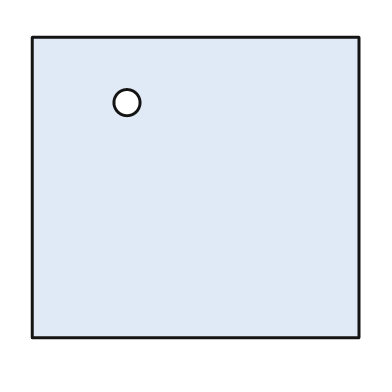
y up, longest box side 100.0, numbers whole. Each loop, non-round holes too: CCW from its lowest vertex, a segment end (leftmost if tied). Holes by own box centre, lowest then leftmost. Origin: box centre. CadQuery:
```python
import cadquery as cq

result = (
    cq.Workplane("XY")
    .moveTo(-50.0, -46.0)
    .lineTo(50.0, -46.0)
    .lineTo(50.0, 46.0)
    .lineTo(-50.0, 46.0)
    .close()
    .moveTo(-21.0, 26.0)
    .circle(4.0)
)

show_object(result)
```